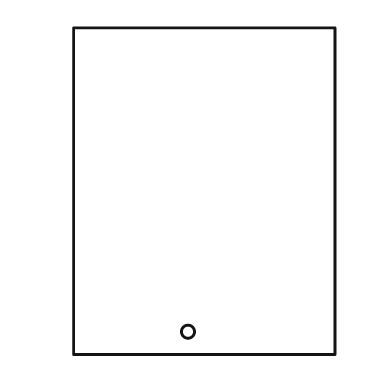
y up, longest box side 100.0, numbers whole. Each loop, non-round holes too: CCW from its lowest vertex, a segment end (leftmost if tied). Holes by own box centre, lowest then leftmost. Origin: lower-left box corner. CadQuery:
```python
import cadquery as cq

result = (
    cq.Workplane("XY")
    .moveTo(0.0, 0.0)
    .lineTo(80.0, 0.0)
    .lineTo(80.0, 100.0)
    .lineTo(0.0, 100.0)
    .close()
    .moveTo(35.0, 7.0)
    .circle(2.0)
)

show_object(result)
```